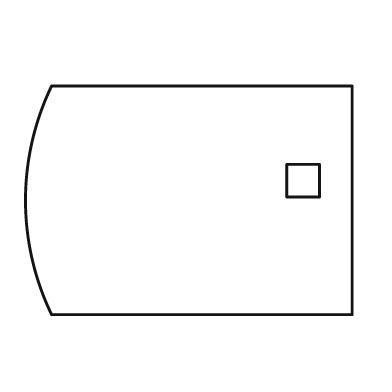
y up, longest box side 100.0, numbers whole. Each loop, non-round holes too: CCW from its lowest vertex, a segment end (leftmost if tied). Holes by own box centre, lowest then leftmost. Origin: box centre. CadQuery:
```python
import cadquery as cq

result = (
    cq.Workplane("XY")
    .moveTo(-42.0, -35.0)
    .lineTo(50.0, -35.0)
    .lineTo(50.0, 35.0)
    .lineTo(-42.0, 35.0)
    .threePointArc((-50.0, 0.0), (-42.0, -35.0))
    .close()
    .moveTo(30.0, 1.0)
    .lineTo(40.0, 1.0)
    .lineTo(40.0, 11.0)
    .lineTo(30.0, 11.0)
    .close()
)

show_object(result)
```